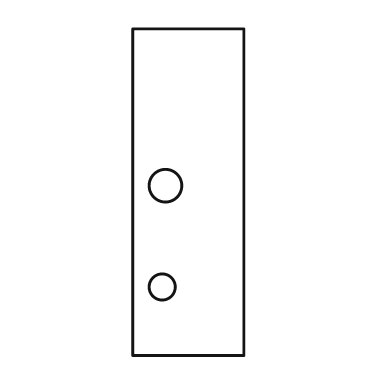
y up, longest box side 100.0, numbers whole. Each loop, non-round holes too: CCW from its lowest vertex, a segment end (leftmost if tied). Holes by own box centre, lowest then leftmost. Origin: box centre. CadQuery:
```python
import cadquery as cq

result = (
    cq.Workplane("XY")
    .moveTo(-17.0, -50.0)
    .lineTo(17.0, -50.0)
    .lineTo(17.0, 50.0)
    .lineTo(-17.0, 50.0)
    .close()
    .moveTo(-8.0, -29.0)
    .circle(4.0)
    .moveTo(-7.0, 2.0)
    .circle(5.0)
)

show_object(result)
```